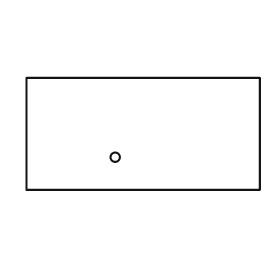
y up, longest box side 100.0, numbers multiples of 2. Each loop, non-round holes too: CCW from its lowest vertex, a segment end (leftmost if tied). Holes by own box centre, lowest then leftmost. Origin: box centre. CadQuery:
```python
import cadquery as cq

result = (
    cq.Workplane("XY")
    .moveTo(-50.0, -24.0)
    .lineTo(50.0, -24.0)
    .lineTo(50.0, 24.0)
    .lineTo(-50.0, 24.0)
    .close()
    .moveTo(-12.0, -10.0)
    .circle(2.0)
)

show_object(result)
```